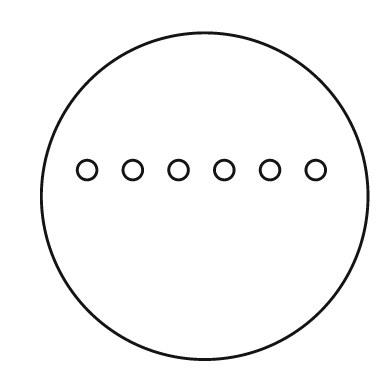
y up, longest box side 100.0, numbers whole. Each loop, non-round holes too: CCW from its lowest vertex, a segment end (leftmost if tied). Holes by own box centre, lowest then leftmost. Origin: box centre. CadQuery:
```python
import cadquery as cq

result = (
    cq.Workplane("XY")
    .moveTo(0.0, 0.0)
    .circle(50.0)
    .moveTo(-36.0, 8.0)
    .circle(3.0)
    .moveTo(-22.0, 8.0)
    .circle(3.0)
    .moveTo(-8.0, 8.0)
    .circle(3.0)
    .moveTo(6.0, 8.0)
    .circle(3.0)
    .moveTo(20.0, 8.0)
    .circle(3.0)
    .moveTo(34.0, 8.0)
    .circle(3.0)
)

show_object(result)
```